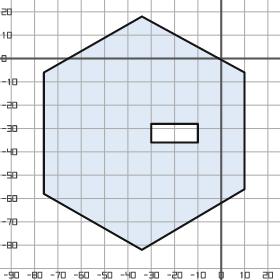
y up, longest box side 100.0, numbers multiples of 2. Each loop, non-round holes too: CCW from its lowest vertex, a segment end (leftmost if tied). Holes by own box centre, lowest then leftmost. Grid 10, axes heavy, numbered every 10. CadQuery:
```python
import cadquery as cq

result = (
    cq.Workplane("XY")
    .moveTo(-34.0, -82.0)
    .lineTo(10.0, -56.0)
    .lineTo(10.0, -6.0)
    .lineTo(-34.0, 18.0)
    .lineTo(-76.0, -6.0)
    .lineTo(-76.0, -58.0)
    .close()
    .moveTo(-30.0, -36.0)
    .lineTo(-10.0, -36.0)
    .lineTo(-10.0, -28.0)
    .lineTo(-30.0, -28.0)
    .close()
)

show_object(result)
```